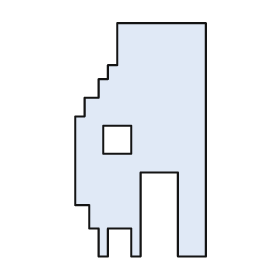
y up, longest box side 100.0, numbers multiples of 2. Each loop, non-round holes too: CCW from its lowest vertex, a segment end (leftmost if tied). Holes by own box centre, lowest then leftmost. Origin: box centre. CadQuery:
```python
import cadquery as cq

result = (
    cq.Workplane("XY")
    .moveTo(-18.0, -50.0)
    .lineTo(-14.0, -50.0)
    .lineTo(-14.0, -38.0)
    .lineTo(-4.0, -38.0)
    .lineTo(-4.0, -50.0)
    .lineTo(0.0, -50.0)
    .lineTo(0.0, -14.0)
    .lineTo(16.0, -14.0)
    .lineTo(16.0, -50.0)
    .lineTo(28.0, -50.0)
    .lineTo(28.0, 50.0)
    .lineTo(-10.0, 50.0)
    .lineTo(-10.0, 32.0)
    .lineTo(-14.0, 32.0)
    .lineTo(-14.0, 26.0)
    .lineTo(-18.0, 26.0)
    .lineTo(-18.0, 18.0)
    .lineTo(-24.0, 18.0)
    .lineTo(-24.0, 10.0)
    .lineTo(-28.0, 10.0)
    .lineTo(-28.0, -28.0)
    .lineTo(-22.0, -28.0)
    .lineTo(-22.0, -38.0)
    .lineTo(-18.0, -38.0)
    .close()
    .moveTo(-16.0, -6.0)
    .lineTo(-4.0, -6.0)
    .lineTo(-4.0, 6.0)
    .lineTo(-16.0, 6.0)
    .close()
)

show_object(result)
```